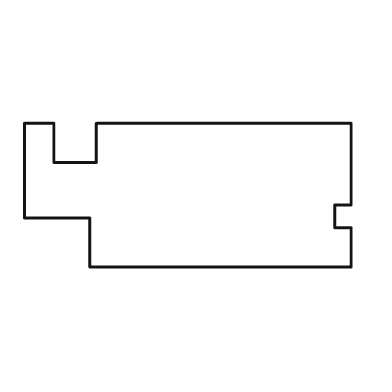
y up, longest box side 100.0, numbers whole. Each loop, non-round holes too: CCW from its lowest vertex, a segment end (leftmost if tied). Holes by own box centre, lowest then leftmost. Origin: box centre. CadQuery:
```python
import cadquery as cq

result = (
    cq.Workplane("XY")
    .moveTo(-30.0, -22.0)
    .lineTo(50.0, -22.0)
    .lineTo(50.0, -10.0)
    .lineTo(45.0, -10.0)
    .lineTo(45.0, -3.0)
    .lineTo(50.0, -3.0)
    .lineTo(50.0, 22.0)
    .lineTo(-28.0, 22.0)
    .lineTo(-28.0, 10.0)
    .lineTo(-41.0, 10.0)
    .lineTo(-41.0, 22.0)
    .lineTo(-50.0, 22.0)
    .lineTo(-50.0, -7.0)
    .lineTo(-30.0, -7.0)
    .close()
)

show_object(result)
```